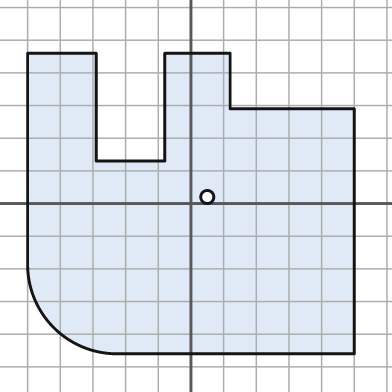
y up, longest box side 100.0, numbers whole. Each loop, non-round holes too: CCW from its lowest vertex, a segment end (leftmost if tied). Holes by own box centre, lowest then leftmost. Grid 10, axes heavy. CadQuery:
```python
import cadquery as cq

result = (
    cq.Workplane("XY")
    .moveTo(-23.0, -46.0)
    .lineTo(50.0, -46.0)
    .lineTo(50.0, 29.0)
    .lineTo(12.0, 29.0)
    .lineTo(12.0, 46.0)
    .lineTo(-8.0, 46.0)
    .lineTo(-8.0, 13.0)
    .lineTo(-29.0, 13.0)
    .lineTo(-29.0, 46.0)
    .lineTo(-50.0, 46.0)
    .lineTo(-50.0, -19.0)
    .threePointArc((-42.0, -38.0), (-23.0, -46.0))
    .close()
    .moveTo(5.0, 2.0)
    .circle(2.0)
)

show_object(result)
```